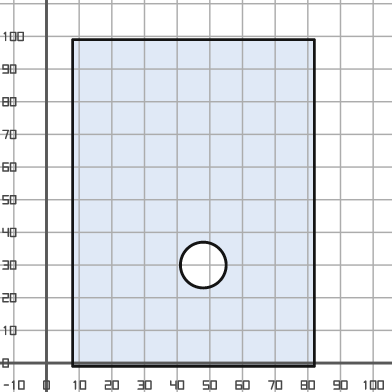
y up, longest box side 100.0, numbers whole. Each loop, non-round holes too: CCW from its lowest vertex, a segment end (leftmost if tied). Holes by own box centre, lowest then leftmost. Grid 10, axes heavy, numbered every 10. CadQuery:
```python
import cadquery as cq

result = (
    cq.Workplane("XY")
    .moveTo(8.0, -1.0)
    .lineTo(82.0, -1.0)
    .lineTo(82.0, 99.0)
    .lineTo(8.0, 99.0)
    .close()
    .moveTo(48.0, 30.0)
    .circle(7.0)
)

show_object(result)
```